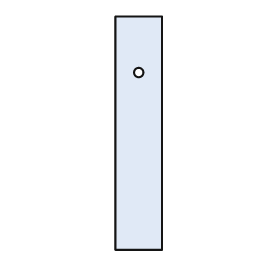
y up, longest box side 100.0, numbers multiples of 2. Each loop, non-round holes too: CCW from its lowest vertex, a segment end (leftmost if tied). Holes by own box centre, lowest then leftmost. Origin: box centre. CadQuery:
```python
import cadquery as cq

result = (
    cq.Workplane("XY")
    .moveTo(-10.0, -50.0)
    .lineTo(10.0, -50.0)
    .lineTo(10.0, 50.0)
    .lineTo(-10.0, 50.0)
    .close()
    .moveTo(0.0, 26.0)
    .circle(2.0)
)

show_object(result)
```